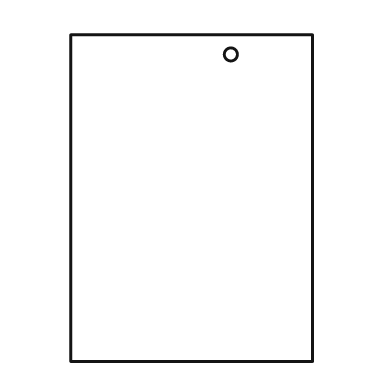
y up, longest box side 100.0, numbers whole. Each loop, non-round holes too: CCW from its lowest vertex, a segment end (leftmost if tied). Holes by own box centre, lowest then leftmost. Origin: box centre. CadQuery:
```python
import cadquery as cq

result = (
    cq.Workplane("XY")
    .moveTo(-37.0, -50.0)
    .lineTo(37.0, -50.0)
    .lineTo(37.0, 50.0)
    .lineTo(-37.0, 50.0)
    .close()
    .moveTo(12.0, 44.0)
    .circle(2.0)
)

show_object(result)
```